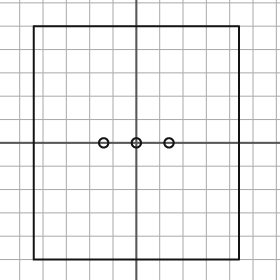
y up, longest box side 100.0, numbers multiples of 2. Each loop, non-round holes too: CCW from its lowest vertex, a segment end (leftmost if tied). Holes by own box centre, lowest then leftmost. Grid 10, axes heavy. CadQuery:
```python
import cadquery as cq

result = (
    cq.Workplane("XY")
    .moveTo(-44.0, -50.0)
    .lineTo(44.0, -50.0)
    .lineTo(44.0, 50.0)
    .lineTo(-44.0, 50.0)
    .close()
    .moveTo(-14.0, 0.0)
    .circle(2.0)
    .moveTo(0.0, 0.0)
    .circle(2.0)
    .moveTo(14.0, 0.0)
    .circle(2.0)
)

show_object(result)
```